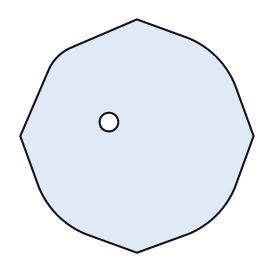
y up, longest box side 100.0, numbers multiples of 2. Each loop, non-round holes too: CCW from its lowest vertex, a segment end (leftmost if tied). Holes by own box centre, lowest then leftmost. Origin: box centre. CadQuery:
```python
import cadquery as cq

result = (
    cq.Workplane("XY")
    .moveTo(0.0, -50.0)
    .lineTo(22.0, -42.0)
    .threePointArc((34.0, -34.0), (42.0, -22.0))
    .lineTo(50.0, 0.0)
    .lineTo(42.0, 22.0)
    .threePointArc((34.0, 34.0), (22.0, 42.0))
    .lineTo(0.0, 50.0)
    .lineTo(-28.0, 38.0)
    .threePointArc((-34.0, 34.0), (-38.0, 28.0))
    .lineTo(-50.0, 0.0)
    .lineTo(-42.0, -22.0)
    .threePointArc((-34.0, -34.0), (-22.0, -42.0))
    .close()
    .moveTo(-12.0, 6.0)
    .circle(4.0)
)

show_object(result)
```